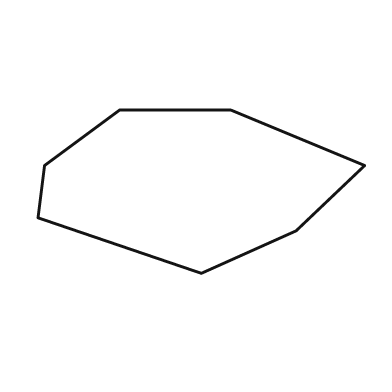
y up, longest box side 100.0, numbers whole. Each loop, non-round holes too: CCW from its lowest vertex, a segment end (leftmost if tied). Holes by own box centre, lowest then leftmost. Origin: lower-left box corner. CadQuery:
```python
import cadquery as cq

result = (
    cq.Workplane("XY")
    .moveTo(50.0, 0.0)
    .lineTo(79.0, 13.0)
    .lineTo(100.0, 33.0)
    .lineTo(59.0, 50.0)
    .lineTo(25.0, 50.0)
    .lineTo(2.0, 33.0)
    .lineTo(0.0, 17.0)
    .close()
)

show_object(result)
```